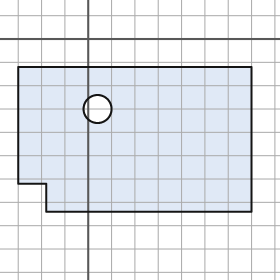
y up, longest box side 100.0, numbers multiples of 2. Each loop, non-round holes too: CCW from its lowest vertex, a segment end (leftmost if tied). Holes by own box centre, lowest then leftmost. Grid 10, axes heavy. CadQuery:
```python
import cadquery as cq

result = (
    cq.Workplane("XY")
    .moveTo(-18.0, -74.0)
    .lineTo(70.0, -74.0)
    .lineTo(70.0, -12.0)
    .lineTo(-30.0, -12.0)
    .lineTo(-30.0, -62.0)
    .lineTo(-18.0, -62.0)
    .close()
    .moveTo(4.0, -30.0)
    .circle(6.0)
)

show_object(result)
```